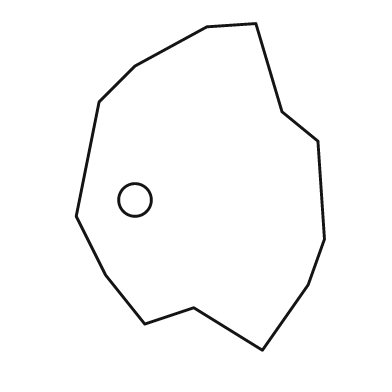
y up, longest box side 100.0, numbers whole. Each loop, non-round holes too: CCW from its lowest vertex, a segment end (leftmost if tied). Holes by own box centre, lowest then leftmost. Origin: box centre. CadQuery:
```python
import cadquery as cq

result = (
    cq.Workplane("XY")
    .moveTo(19.0, -50.0)
    .lineTo(33.0, -30.0)
    .lineTo(38.0, -16.0)
    .lineTo(36.0, 14.0)
    .lineTo(25.0, 23.0)
    .lineTo(17.0, 50.0)
    .lineTo(2.0, 49.0)
    .lineTo(-20.0, 37.0)
    .lineTo(-31.0, 26.0)
    .lineTo(-38.0, -9.0)
    .lineTo(-29.0, -27.0)
    .lineTo(-17.0, -42.0)
    .lineTo(-2.0, -37.0)
    .close()
    .moveTo(-20.0, -4.0)
    .circle(5.0)
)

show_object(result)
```